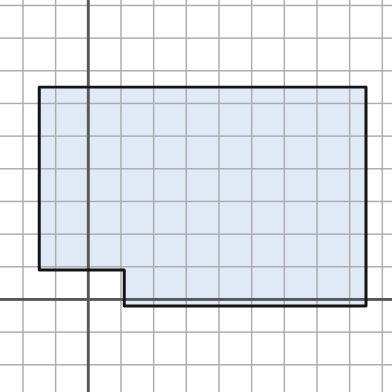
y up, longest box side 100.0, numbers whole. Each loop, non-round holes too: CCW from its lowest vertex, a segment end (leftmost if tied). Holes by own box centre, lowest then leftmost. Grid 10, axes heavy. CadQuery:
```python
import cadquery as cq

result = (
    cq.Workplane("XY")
    .moveTo(11.0, -2.0)
    .lineTo(85.0, -2.0)
    .lineTo(85.0, 65.0)
    .lineTo(-15.0, 65.0)
    .lineTo(-15.0, 9.0)
    .lineTo(11.0, 9.0)
    .close()
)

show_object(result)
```